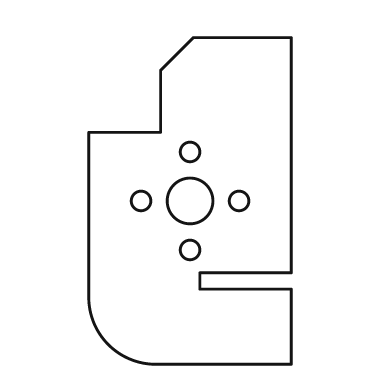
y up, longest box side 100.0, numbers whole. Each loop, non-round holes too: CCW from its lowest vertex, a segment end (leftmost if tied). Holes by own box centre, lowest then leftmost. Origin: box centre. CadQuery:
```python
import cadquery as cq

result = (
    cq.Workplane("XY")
    .moveTo(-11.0, -50.0)
    .lineTo(31.0, -50.0)
    .lineTo(31.0, -27.0)
    .lineTo(3.0, -27.0)
    .lineTo(3.0, -22.0)
    .lineTo(31.0, -22.0)
    .lineTo(31.0, 50.0)
    .lineTo(1.0, 50.0)
    .lineTo(-9.0, 40.0)
    .lineTo(-9.0, 21.0)
    .lineTo(-31.0, 21.0)
    .lineTo(-31.0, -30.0)
    .threePointArc((-25.0, -44.0), (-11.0, -50.0))
    .close()
    .moveTo(0.0, -15.0)
    .circle(3.0)
    .moveTo(-15.0, 0.0)
    .circle(3.0)
    .moveTo(0.0, 0.0)
    .circle(7.0)
    .moveTo(15.0, 0.0)
    .circle(3.0)
    .moveTo(0.0, 15.0)
    .circle(3.0)
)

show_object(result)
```